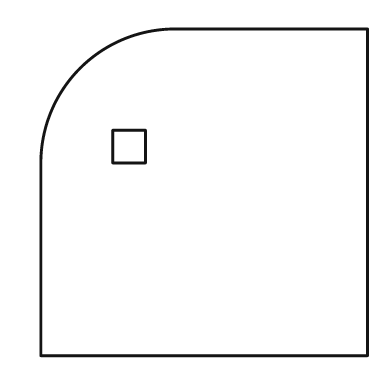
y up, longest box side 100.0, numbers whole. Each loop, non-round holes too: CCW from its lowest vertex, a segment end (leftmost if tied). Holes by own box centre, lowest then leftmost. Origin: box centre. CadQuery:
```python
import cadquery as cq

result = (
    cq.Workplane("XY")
    .moveTo(-50.0, -50.0)
    .lineTo(50.0, -50.0)
    .lineTo(50.0, 50.0)
    .lineTo(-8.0, 50.0)
    .threePointArc((-38.0, 38.0), (-50.0, 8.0))
    .close()
    .moveTo(-28.0, 9.0)
    .lineTo(-18.0, 9.0)
    .lineTo(-18.0, 19.0)
    .lineTo(-28.0, 19.0)
    .close()
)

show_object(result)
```